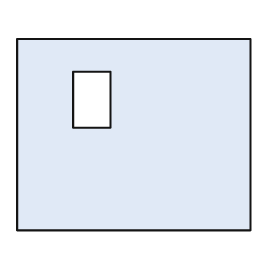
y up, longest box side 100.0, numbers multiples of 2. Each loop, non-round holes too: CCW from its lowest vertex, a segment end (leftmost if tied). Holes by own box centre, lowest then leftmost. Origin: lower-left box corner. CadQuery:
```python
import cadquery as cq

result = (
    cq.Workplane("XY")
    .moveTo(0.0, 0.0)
    .lineTo(100.0, 0.0)
    .lineTo(100.0, 82.0)
    .lineTo(0.0, 82.0)
    .close()
    .moveTo(24.0, 44.0)
    .lineTo(40.0, 44.0)
    .lineTo(40.0, 68.0)
    .lineTo(24.0, 68.0)
    .close()
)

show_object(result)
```